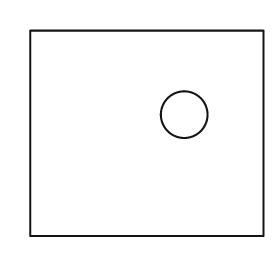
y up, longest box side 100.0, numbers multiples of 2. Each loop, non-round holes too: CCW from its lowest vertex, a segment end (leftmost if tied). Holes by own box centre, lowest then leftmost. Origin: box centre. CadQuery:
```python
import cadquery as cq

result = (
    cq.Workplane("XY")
    .moveTo(-50.0, -44.0)
    .lineTo(50.0, -44.0)
    .lineTo(50.0, 44.0)
    .lineTo(-50.0, 44.0)
    .close()
    .moveTo(16.0, 8.0)
    .circle(10.0)
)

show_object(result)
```